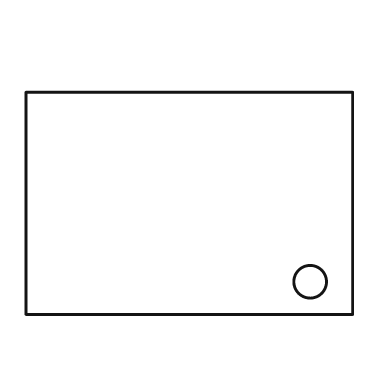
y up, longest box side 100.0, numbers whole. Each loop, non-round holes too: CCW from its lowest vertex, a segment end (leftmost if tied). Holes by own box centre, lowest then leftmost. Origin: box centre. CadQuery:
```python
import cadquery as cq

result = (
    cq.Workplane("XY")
    .moveTo(-50.0, -34.0)
    .lineTo(50.0, -34.0)
    .lineTo(50.0, 34.0)
    .lineTo(-50.0, 34.0)
    .close()
    .moveTo(37.0, -24.0)
    .circle(5.0)
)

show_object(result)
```